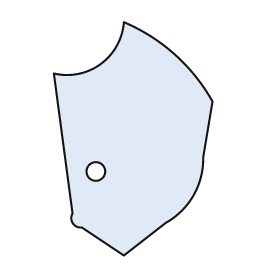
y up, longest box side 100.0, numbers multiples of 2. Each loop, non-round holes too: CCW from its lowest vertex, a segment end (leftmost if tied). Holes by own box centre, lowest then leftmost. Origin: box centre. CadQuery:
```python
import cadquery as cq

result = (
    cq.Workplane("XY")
    .moveTo(-4.0, -50.0)
    .lineTo(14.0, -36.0)
    .threePointArc((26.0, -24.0), (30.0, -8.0))
    .lineTo(34.0, 16.0)
    .threePointArc((18.0, 36.0), (-4.0, 50.0))
    .threePointArc((-14.0, 32.0), (-34.0, 28.0))
    .lineTo(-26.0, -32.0)
    .threePointArc((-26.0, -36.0), (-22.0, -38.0))
    .close()
    .moveTo(-16.0, -14.0)
    .circle(4.0)
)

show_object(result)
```